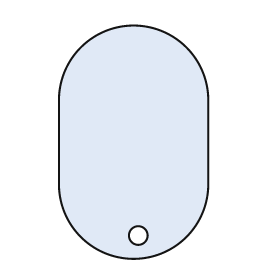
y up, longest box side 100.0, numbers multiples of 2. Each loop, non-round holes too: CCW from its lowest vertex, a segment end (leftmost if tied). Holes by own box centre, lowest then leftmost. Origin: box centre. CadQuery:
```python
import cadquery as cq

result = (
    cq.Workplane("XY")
    .moveTo(-32.0, -18.0)
    .threePointArc((0.0, -50.0), (32.0, -18.0))
    .lineTo(32.0, 18.0)
    .threePointArc((0.0, 50.0), (-32.0, 18.0))
    .close()
    .moveTo(2.0, -40.0)
    .circle(4.0)
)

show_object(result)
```